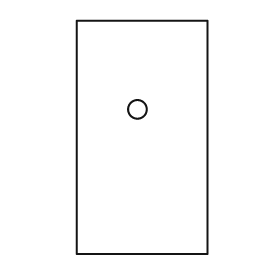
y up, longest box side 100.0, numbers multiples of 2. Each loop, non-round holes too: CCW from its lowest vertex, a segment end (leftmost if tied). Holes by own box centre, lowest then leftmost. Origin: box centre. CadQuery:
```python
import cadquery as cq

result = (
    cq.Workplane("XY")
    .moveTo(-28.0, -50.0)
    .lineTo(28.0, -50.0)
    .lineTo(28.0, 50.0)
    .lineTo(-28.0, 50.0)
    .close()
    .moveTo(-2.0, 12.0)
    .circle(4.0)
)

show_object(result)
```